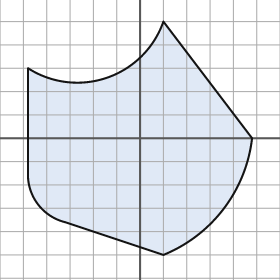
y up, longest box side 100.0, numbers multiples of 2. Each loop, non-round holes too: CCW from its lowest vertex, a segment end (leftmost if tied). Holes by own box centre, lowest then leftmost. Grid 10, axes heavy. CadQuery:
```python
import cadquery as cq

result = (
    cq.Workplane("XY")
    .moveTo(10.0, -50.0)
    .threePointArc((36.0, -30.0), (48.0, 0.0))
    .lineTo(10.0, 50.0)
    .threePointArc((-14.0, 26.0), (-48.0, 30.0))
    .lineTo(-48.0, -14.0)
    .threePointArc((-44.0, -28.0), (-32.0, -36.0))
    .close()
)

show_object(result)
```